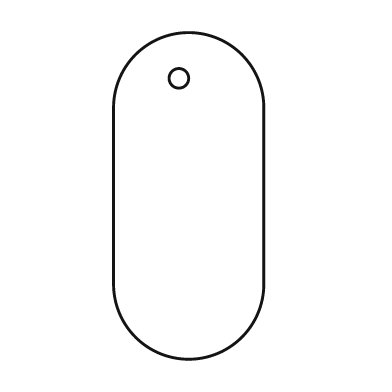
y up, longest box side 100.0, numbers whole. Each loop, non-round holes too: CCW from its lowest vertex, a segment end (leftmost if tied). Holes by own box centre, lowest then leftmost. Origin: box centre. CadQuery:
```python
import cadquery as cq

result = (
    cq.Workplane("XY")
    .moveTo(-23.0, -27.0)
    .threePointArc((0.0, -50.0), (23.0, -27.0))
    .lineTo(23.0, 27.0)
    .threePointArc((0.0, 50.0), (-23.0, 27.0))
    .close()
    .moveTo(-3.0, 36.0)
    .circle(3.0)
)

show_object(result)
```